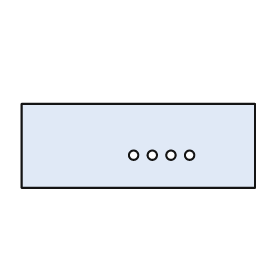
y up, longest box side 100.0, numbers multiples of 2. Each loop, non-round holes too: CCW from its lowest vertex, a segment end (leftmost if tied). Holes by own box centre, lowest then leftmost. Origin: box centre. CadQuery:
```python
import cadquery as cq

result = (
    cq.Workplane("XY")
    .moveTo(-50.0, -18.0)
    .lineTo(50.0, -18.0)
    .lineTo(50.0, 18.0)
    .lineTo(-50.0, 18.0)
    .close()
    .moveTo(-2.0, -4.0)
    .circle(2.0)
    .moveTo(6.0, -4.0)
    .circle(2.0)
    .moveTo(14.0, -4.0)
    .circle(2.0)
    .moveTo(22.0, -4.0)
    .circle(2.0)
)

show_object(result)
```